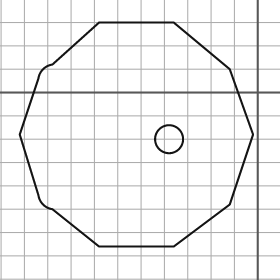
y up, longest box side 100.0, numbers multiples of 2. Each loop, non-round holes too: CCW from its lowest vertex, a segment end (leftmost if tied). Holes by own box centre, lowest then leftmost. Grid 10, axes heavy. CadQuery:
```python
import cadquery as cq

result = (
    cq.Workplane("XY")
    .moveTo(-68.0, -66.0)
    .lineTo(-36.0, -66.0)
    .lineTo(-12.0, -48.0)
    .lineTo(-2.0, -18.0)
    .lineTo(-12.0, 10.0)
    .lineTo(-36.0, 30.0)
    .lineTo(-68.0, 30.0)
    .lineTo(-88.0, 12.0)
    .threePointArc((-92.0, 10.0), (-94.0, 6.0))
    .lineTo(-102.0, -18.0)
    .lineTo(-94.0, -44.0)
    .threePointArc((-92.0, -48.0), (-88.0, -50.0))
    .close()
    .moveTo(-38.0, -20.0)
    .circle(6.0)
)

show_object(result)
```